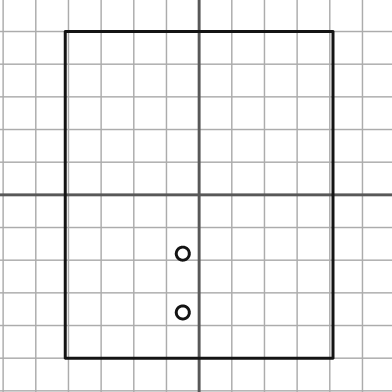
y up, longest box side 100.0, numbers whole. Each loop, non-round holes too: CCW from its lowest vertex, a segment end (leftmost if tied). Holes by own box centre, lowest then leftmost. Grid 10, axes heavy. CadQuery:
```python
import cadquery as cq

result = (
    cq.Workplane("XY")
    .moveTo(-41.0, -50.0)
    .lineTo(41.0, -50.0)
    .lineTo(41.0, 50.0)
    .lineTo(-41.0, 50.0)
    .close()
    .moveTo(-5.0, -36.0)
    .circle(2.0)
    .moveTo(-5.0, -18.0)
    .circle(2.0)
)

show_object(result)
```